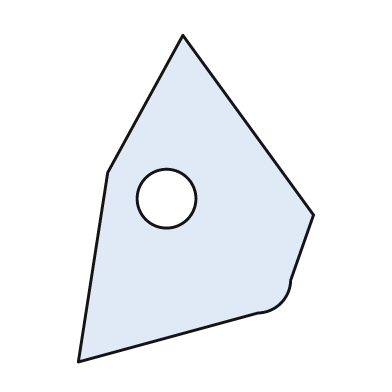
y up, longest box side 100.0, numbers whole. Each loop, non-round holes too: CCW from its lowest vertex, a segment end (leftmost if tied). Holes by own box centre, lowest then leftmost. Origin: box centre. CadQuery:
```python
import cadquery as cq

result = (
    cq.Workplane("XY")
    .moveTo(-36.0, -50.0)
    .lineTo(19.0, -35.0)
    .threePointArc((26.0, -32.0), (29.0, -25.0))
    .lineTo(36.0, -5.0)
    .lineTo(-4.0, 50.0)
    .lineTo(-27.0, 8.0)
    .close()
    .moveTo(-9.0, 0.0)
    .circle(9.0)
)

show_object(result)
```